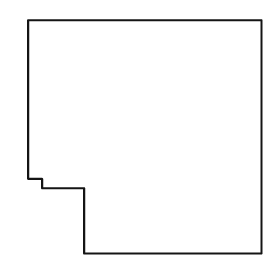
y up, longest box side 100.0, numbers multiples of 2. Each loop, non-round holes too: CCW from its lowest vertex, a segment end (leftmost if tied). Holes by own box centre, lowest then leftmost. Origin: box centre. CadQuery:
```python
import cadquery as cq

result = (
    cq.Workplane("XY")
    .moveTo(-26.0, -50.0)
    .lineTo(50.0, -50.0)
    .lineTo(50.0, 50.0)
    .lineTo(-50.0, 50.0)
    .lineTo(-50.0, -18.0)
    .lineTo(-44.0, -18.0)
    .lineTo(-44.0, -22.0)
    .lineTo(-26.0, -22.0)
    .close()
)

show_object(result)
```